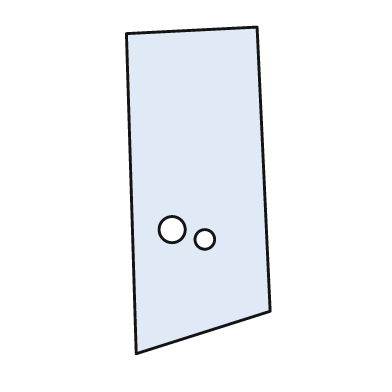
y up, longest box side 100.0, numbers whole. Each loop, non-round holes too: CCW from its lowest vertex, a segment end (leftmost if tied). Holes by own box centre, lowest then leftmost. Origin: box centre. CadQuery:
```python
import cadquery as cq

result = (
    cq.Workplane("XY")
    .moveTo(-19.0, -50.0)
    .lineTo(22.0, -37.0)
    .lineTo(18.0, 50.0)
    .lineTo(-22.0, 48.0)
    .close()
    .moveTo(2.0, -15.0)
    .circle(3.0)
    .moveTo(-8.0, -12.0)
    .circle(4.0)
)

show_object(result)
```